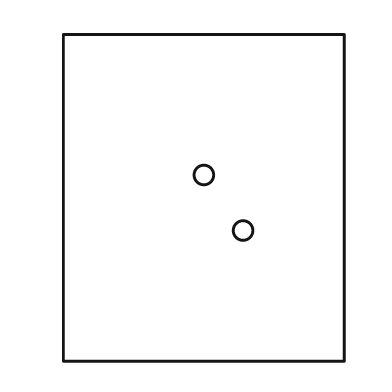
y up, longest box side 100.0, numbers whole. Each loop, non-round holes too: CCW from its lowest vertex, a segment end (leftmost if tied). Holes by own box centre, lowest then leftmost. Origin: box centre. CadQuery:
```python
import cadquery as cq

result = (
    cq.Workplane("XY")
    .moveTo(-43.0, -50.0)
    .lineTo(43.0, -50.0)
    .lineTo(43.0, 50.0)
    .lineTo(-43.0, 50.0)
    .close()
    .moveTo(12.0, -10.0)
    .circle(3.0)
    .moveTo(0.0, 7.0)
    .circle(3.0)
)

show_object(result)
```